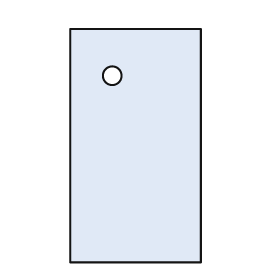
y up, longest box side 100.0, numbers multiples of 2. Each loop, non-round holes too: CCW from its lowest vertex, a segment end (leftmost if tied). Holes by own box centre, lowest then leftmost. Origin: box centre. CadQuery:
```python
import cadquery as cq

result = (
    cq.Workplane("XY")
    .moveTo(-28.0, -50.0)
    .lineTo(28.0, -50.0)
    .lineTo(28.0, 50.0)
    .lineTo(-28.0, 50.0)
    .close()
    .moveTo(-10.0, 30.0)
    .circle(4.0)
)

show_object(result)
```